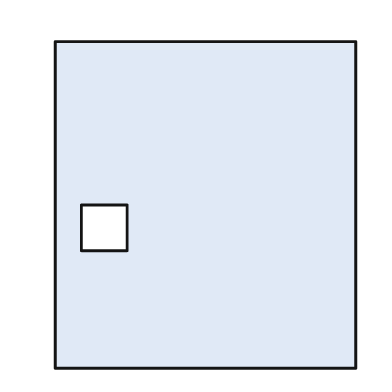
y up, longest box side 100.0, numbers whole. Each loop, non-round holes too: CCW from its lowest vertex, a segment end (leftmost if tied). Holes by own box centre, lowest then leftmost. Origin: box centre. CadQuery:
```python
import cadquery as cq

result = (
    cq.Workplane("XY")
    .moveTo(-46.0, -50.0)
    .lineTo(46.0, -50.0)
    .lineTo(46.0, 50.0)
    .lineTo(-46.0, 50.0)
    .close()
    .moveTo(-38.0, -14.0)
    .lineTo(-24.0, -14.0)
    .lineTo(-24.0, 0.0)
    .lineTo(-38.0, 0.0)
    .close()
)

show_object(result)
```